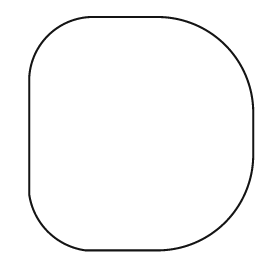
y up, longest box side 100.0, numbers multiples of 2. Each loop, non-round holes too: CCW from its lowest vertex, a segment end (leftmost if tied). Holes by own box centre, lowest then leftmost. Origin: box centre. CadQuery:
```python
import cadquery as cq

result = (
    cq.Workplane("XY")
    .moveTo(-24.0, -50.0)
    .lineTo(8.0, -50.0)
    .threePointArc((36.0, -38.0), (48.0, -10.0))
    .lineTo(48.0, 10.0)
    .threePointArc((36.0, 38.0), (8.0, 50.0))
    .lineTo(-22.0, 50.0)
    .threePointArc((-40.0, 42.0), (-48.0, 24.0))
    .lineTo(-48.0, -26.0)
    .threePointArc((-40.0, -42.0), (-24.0, -50.0))
    .close()
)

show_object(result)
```